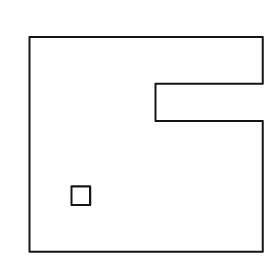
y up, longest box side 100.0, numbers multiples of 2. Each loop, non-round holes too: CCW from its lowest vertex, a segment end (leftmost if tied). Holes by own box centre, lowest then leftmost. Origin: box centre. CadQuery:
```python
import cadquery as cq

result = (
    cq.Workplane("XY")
    .moveTo(-50.0, -46.0)
    .lineTo(50.0, -46.0)
    .lineTo(50.0, 10.0)
    .lineTo(4.0, 10.0)
    .lineTo(4.0, 26.0)
    .lineTo(50.0, 26.0)
    .lineTo(50.0, 46.0)
    .lineTo(-50.0, 46.0)
    .close()
    .moveTo(-32.0, -26.0)
    .lineTo(-24.0, -26.0)
    .lineTo(-24.0, -18.0)
    .lineTo(-32.0, -18.0)
    .close()
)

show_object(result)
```